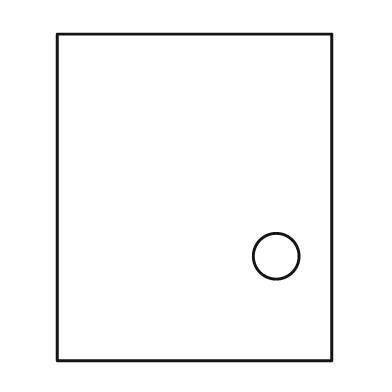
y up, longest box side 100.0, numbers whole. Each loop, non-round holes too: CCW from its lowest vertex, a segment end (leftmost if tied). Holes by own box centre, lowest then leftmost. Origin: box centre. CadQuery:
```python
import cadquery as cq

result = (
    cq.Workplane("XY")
    .moveTo(-42.0, -50.0)
    .lineTo(42.0, -50.0)
    .lineTo(42.0, 50.0)
    .lineTo(-42.0, 50.0)
    .close()
    .moveTo(25.0, -18.0)
    .circle(7.0)
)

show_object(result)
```